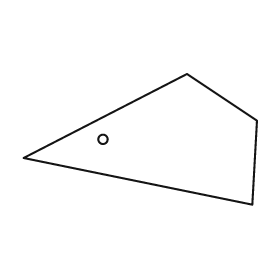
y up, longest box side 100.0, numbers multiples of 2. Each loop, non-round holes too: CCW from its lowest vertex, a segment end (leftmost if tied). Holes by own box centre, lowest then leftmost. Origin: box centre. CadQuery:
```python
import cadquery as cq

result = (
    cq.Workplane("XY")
    .moveTo(48.0, -28.0)
    .lineTo(50.0, 8.0)
    .lineTo(20.0, 28.0)
    .lineTo(-50.0, -8.0)
    .close()
    .moveTo(-16.0, 0.0)
    .circle(2.0)
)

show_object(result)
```